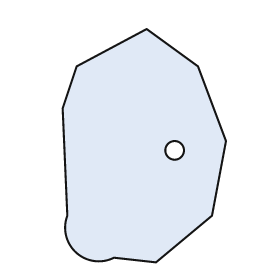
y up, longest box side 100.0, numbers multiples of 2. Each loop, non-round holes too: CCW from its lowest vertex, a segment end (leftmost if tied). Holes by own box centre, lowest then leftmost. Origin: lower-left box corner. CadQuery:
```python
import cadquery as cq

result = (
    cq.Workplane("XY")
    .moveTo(40.0, 0.0)
    .lineTo(64.0, 20.0)
    .lineTo(70.0, 52.0)
    .lineTo(58.0, 84.0)
    .lineTo(36.0, 100.0)
    .lineTo(6.0, 84.0)
    .lineTo(0.0, 66.0)
    .lineTo(2.0, 20.0)
    .threePointArc((6.0, 4.0), (22.0, 2.0))
    .close()
    .moveTo(48.0, 48.0)
    .circle(4.0)
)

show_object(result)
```